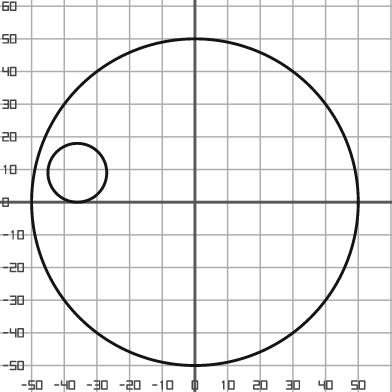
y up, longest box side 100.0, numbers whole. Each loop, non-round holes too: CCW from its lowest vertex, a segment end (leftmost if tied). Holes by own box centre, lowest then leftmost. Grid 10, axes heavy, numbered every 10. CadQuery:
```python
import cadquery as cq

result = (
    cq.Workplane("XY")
    .moveTo(0.0, 0.0)
    .circle(50.0)
    .moveTo(-36.0, 9.0)
    .circle(9.0)
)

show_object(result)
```